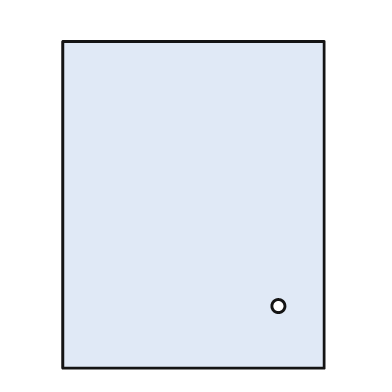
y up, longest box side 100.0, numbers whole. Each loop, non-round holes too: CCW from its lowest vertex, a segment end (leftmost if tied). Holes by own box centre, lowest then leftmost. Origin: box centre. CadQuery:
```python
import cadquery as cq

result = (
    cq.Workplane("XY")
    .moveTo(-40.0, -50.0)
    .lineTo(40.0, -50.0)
    .lineTo(40.0, 50.0)
    .lineTo(-40.0, 50.0)
    .close()
    .moveTo(26.0, -31.0)
    .circle(2.0)
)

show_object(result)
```